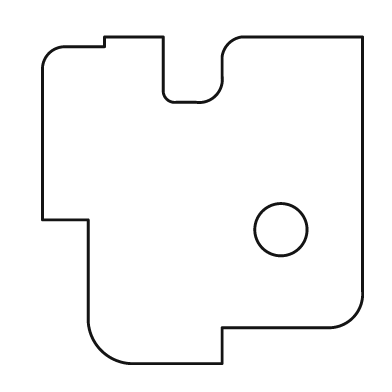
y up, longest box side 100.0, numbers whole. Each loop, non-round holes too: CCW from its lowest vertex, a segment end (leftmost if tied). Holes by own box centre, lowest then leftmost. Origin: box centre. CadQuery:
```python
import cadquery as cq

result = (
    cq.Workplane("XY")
    .moveTo(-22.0, -50.0)
    .lineTo(6.0, -50.0)
    .lineTo(6.0, -39.0)
    .lineTo(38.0, -39.0)
    .threePointArc((46.0, -36.0), (49.0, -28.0))
    .lineTo(49.0, 50.0)
    .lineTo(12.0, 50.0)
    .threePointArc((8.0, 48.0), (6.0, 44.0))
    .lineTo(6.0, 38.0)
    .threePointArc((4.0, 32.0), (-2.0, 30.0))
    .lineTo(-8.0, 30.0)
    .threePointArc((-11.0, 31.0), (-12.0, 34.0))
    .lineTo(-12.0, 50.0)
    .lineTo(-30.0, 50.0)
    .lineTo(-30.0, 47.0)
    .lineTo(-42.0, 47.0)
    .threePointArc((-47.0, 45.0), (-49.0, 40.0))
    .lineTo(-49.0, -6.0)
    .lineTo(-35.0, -6.0)
    .lineTo(-35.0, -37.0)
    .threePointArc((-31.0, -46.0), (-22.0, -50.0))
    .close()
    .moveTo(24.0, -9.0)
    .circle(8.0)
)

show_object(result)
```